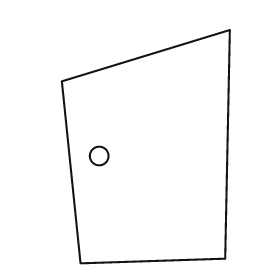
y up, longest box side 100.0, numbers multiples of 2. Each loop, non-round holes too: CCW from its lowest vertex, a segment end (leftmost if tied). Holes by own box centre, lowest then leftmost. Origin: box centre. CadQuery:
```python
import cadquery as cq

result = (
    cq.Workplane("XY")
    .moveTo(-28.0, -50.0)
    .lineTo(34.0, -48.0)
    .lineTo(36.0, 50.0)
    .lineTo(-36.0, 28.0)
    .close()
    .moveTo(-20.0, -4.0)
    .circle(4.0)
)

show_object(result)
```